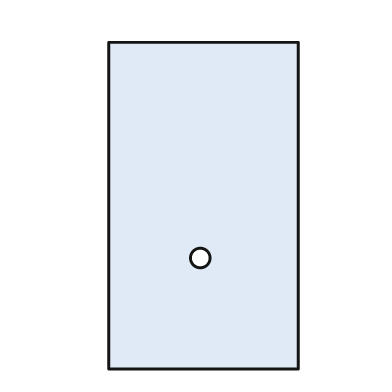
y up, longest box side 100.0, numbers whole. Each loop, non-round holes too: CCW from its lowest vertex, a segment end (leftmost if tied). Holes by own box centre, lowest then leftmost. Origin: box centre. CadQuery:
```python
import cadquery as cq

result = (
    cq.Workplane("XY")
    .moveTo(-29.0, -50.0)
    .lineTo(29.0, -50.0)
    .lineTo(29.0, 50.0)
    .lineTo(-29.0, 50.0)
    .close()
    .moveTo(-1.0, -16.0)
    .circle(3.0)
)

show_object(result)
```